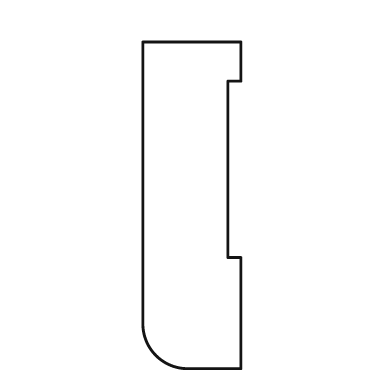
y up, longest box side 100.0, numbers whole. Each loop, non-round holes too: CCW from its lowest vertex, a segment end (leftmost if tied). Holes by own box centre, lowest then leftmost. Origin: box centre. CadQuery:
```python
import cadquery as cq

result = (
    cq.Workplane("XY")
    .moveTo(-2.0, -50.0)
    .lineTo(15.0, -50.0)
    .lineTo(15.0, -16.0)
    .lineTo(11.0, -16.0)
    .lineTo(11.0, 38.0)
    .lineTo(15.0, 38.0)
    .lineTo(15.0, 50.0)
    .lineTo(-15.0, 50.0)
    .lineTo(-15.0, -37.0)
    .threePointArc((-11.0, -46.0), (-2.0, -50.0))
    .close()
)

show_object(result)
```